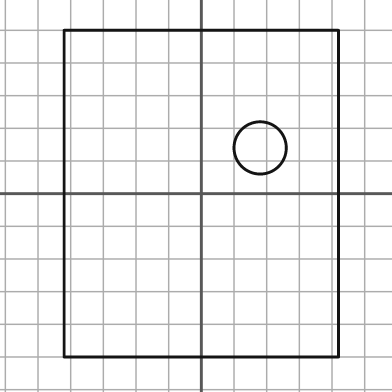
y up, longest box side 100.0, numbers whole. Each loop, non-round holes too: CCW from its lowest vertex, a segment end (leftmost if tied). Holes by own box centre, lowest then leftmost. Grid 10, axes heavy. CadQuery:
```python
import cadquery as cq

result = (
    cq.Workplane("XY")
    .moveTo(-42.0, -50.0)
    .lineTo(42.0, -50.0)
    .lineTo(42.0, 50.0)
    .lineTo(-42.0, 50.0)
    .close()
    .moveTo(18.0, 14.0)
    .circle(8.0)
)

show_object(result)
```